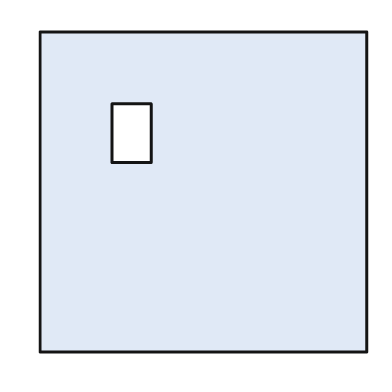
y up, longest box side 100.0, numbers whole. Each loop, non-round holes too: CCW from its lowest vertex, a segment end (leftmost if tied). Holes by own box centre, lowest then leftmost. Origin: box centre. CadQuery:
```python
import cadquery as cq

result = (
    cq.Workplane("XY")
    .moveTo(-50.0, -49.0)
    .lineTo(50.0, -49.0)
    .lineTo(50.0, 49.0)
    .lineTo(-50.0, 49.0)
    .close()
    .moveTo(-28.0, 9.0)
    .lineTo(-16.0, 9.0)
    .lineTo(-16.0, 27.0)
    .lineTo(-28.0, 27.0)
    .close()
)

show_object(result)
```